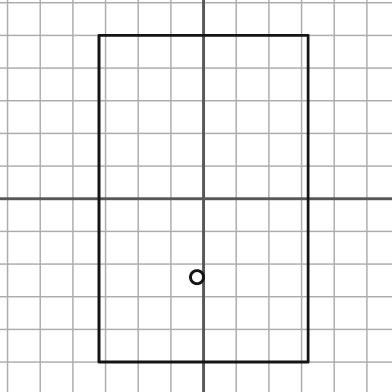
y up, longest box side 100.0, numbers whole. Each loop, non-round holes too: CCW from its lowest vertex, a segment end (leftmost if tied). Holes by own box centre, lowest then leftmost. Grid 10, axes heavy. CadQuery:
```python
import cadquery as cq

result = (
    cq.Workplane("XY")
    .moveTo(-32.0, -50.0)
    .lineTo(32.0, -50.0)
    .lineTo(32.0, 50.0)
    .lineTo(-32.0, 50.0)
    .close()
    .moveTo(-2.0, -24.0)
    .circle(2.0)
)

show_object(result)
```